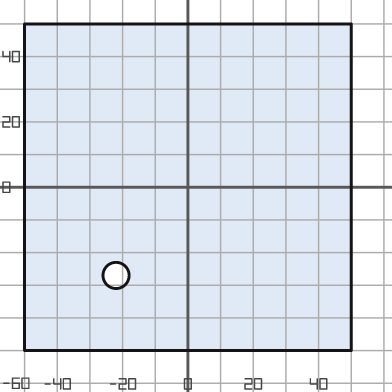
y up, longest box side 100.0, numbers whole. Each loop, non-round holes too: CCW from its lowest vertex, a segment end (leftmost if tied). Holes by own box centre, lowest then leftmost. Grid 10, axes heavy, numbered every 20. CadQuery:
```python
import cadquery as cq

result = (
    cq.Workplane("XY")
    .moveTo(-50.0, -50.0)
    .lineTo(50.0, -50.0)
    .lineTo(50.0, 50.0)
    .lineTo(-50.0, 50.0)
    .close()
    .moveTo(-22.0, -27.0)
    .circle(4.0)
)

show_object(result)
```